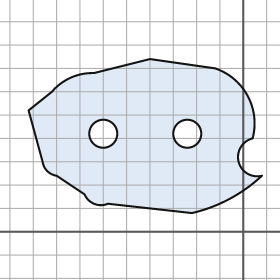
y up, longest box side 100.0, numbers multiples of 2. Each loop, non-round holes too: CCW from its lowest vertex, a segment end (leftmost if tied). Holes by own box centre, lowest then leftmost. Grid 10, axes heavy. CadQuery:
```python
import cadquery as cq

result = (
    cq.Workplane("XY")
    .moveTo(-22.0, 8.0)
    .threePointArc((-6.0, 14.0), (8.0, 24.0))
    .threePointArc((-2.0, 30.0), (4.0, 40.0))
    .threePointArc((2.0, 58.0), (-12.0, 70.0))
    .lineTo(-40.0, 74.0)
    .lineTo(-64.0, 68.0)
    .threePointArc((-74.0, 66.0), (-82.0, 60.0))
    .lineTo(-92.0, 52.0)
    .lineTo(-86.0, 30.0)
    .threePointArc((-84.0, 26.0), (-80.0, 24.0))
    .lineTo(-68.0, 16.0)
    .threePointArc((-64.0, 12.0), (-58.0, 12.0))
    .close()
    .moveTo(-60.0, 42.0)
    .circle(6.0)
    .moveTo(-24.0, 42.0)
    .circle(6.0)
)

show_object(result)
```